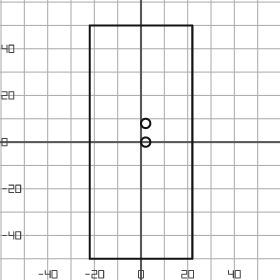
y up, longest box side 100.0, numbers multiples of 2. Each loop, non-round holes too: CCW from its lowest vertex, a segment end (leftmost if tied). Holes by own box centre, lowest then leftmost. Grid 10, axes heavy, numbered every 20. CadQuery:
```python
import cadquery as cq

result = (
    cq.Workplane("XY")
    .moveTo(-22.0, -50.0)
    .lineTo(22.0, -50.0)
    .lineTo(22.0, 50.0)
    .lineTo(-22.0, 50.0)
    .close()
    .moveTo(2.0, 0.0)
    .circle(2.0)
    .moveTo(2.0, 8.0)
    .circle(2.0)
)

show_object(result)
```